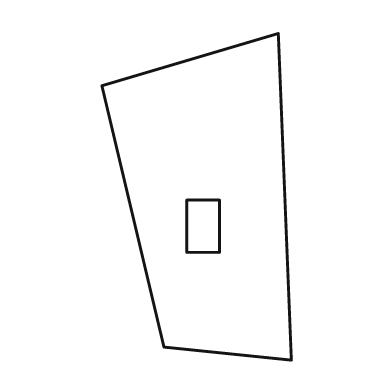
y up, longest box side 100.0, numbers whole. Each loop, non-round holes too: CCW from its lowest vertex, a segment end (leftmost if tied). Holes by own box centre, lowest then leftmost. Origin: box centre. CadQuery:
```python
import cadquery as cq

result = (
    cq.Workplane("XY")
    .moveTo(29.0, -50.0)
    .lineTo(25.0, 50.0)
    .lineTo(-29.0, 34.0)
    .lineTo(-10.0, -46.0)
    .close()
    .moveTo(-3.0, -17.0)
    .lineTo(7.0, -17.0)
    .lineTo(7.0, -1.0)
    .lineTo(-3.0, -1.0)
    .close()
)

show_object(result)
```